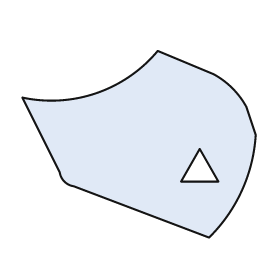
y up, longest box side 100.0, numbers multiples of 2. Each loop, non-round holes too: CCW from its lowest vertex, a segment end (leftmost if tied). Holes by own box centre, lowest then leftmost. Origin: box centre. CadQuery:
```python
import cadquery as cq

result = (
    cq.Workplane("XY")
    .moveTo(30.0, -40.0)
    .threePointArc((44.0, -20.0), (50.0, 4.0))
    .lineTo(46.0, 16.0)
    .threePointArc((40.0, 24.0), (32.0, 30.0))
    .lineTo(8.0, 40.0)
    .threePointArc((-18.0, 22.0), (-50.0, 20.0))
    .lineTo(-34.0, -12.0)
    .threePointArc((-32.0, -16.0), (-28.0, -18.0))
    .close()
    .moveTo(18.0, -16.0)
    .lineTo(34.0, -16.0)
    .lineTo(26.0, -2.0)
    .close()
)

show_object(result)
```